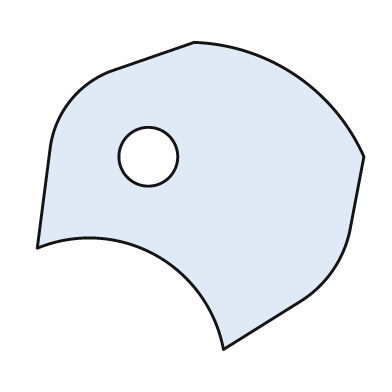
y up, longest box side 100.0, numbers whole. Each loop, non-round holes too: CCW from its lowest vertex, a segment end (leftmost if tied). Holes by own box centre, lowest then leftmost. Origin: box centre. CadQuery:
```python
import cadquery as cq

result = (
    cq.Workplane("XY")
    .moveTo(7.0, -47.0)
    .lineTo(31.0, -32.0)
    .threePointArc((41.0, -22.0), (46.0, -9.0))
    .lineTo(50.0, 12.0)
    .threePointArc((29.0, 37.0), (-2.0, 47.0))
    .lineTo(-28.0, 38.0)
    .threePointArc((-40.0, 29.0), (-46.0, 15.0))
    .lineTo(-50.0, -16.0)
    .threePointArc((-14.0, -18.0), (7.0, -47.0))
    .close()
    .moveTo(-16.0, 12.0)
    .circle(9.0)
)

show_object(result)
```